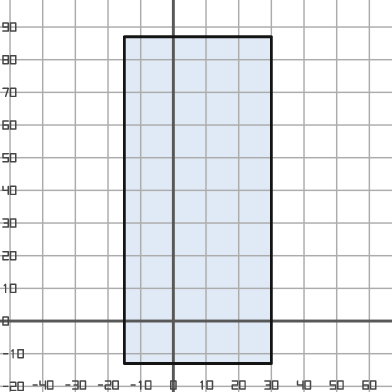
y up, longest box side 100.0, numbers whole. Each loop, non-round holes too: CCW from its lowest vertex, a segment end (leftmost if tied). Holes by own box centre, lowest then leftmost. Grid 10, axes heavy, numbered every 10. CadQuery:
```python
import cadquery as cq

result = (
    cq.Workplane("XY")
    .moveTo(-15.0, -13.0)
    .lineTo(30.0, -13.0)
    .lineTo(30.0, 87.0)
    .lineTo(-15.0, 87.0)
    .close()
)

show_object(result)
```